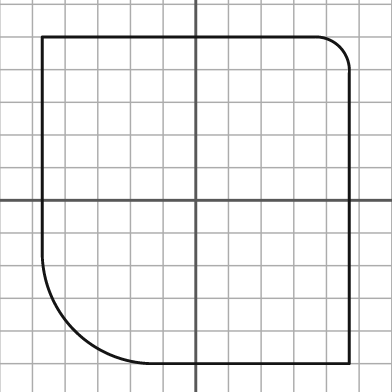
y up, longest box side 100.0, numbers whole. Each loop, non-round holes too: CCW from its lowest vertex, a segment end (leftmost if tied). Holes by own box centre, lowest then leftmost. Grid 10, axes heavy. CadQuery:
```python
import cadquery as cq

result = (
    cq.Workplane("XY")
    .moveTo(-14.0, -50.0)
    .lineTo(47.0, -50.0)
    .lineTo(47.0, 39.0)
    .threePointArc((44.0, 47.0), (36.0, 50.0))
    .lineTo(-47.0, 50.0)
    .lineTo(-47.0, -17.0)
    .threePointArc((-37.0, -40.0), (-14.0, -50.0))
    .close()
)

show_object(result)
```